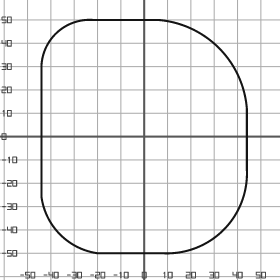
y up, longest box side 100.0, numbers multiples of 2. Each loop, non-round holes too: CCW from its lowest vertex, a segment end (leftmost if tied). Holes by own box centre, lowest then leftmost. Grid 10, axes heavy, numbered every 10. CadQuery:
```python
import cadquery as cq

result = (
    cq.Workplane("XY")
    .moveTo(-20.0, -50.0)
    .lineTo(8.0, -50.0)
    .threePointArc((34.0, -40.0), (44.0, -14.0))
    .lineTo(44.0, 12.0)
    .threePointArc((32.0, 38.0), (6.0, 50.0))
    .lineTo(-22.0, 50.0)
    .threePointArc((-38.0, 44.0), (-44.0, 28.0))
    .lineTo(-44.0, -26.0)
    .threePointArc((-36.0, -42.0), (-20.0, -50.0))
    .close()
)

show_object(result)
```